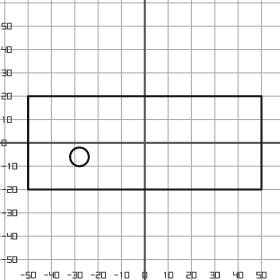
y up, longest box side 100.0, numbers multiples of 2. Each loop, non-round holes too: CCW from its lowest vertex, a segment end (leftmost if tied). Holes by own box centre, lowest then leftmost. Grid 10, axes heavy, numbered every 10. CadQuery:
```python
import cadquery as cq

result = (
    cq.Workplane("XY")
    .moveTo(-50.0, -20.0)
    .lineTo(50.0, -20.0)
    .lineTo(50.0, 20.0)
    .lineTo(-50.0, 20.0)
    .close()
    .moveTo(-28.0, -6.0)
    .circle(4.0)
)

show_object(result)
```